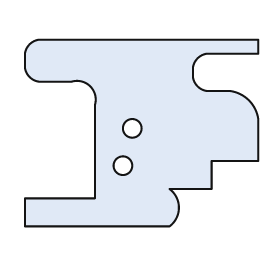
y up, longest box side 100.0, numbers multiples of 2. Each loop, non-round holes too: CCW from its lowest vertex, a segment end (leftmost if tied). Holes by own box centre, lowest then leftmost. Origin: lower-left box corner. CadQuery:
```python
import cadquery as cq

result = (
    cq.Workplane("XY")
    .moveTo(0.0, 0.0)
    .lineTo(62.0, 0.0)
    .threePointArc((66.0, 8.0), (62.0, 16.0))
    .lineTo(80.0, 16.0)
    .lineTo(80.0, 28.0)
    .lineTo(100.0, 28.0)
    .lineTo(100.0, 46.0)
    .threePointArc((96.0, 54.0), (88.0, 58.0))
    .lineTo(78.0, 58.0)
    .threePointArc((74.0, 60.0), (72.0, 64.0))
    .lineTo(72.0, 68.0)
    .threePointArc((74.0, 72.0), (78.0, 74.0))
    .lineTo(100.0, 74.0)
    .lineTo(100.0, 80.0)
    .lineTo(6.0, 80.0)
    .threePointArc((2.0, 78.0), (0.0, 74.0))
    .lineTo(0.0, 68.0)
    .threePointArc((2.0, 64.0), (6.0, 62.0))
    .lineTo(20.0, 62.0)
    .threePointArc((28.0, 60.0), (30.0, 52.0))
    .lineTo(30.0, 12.0)
    .lineTo(0.0, 12.0)
    .close()
    .moveTo(42.0, 26.0)
    .circle(4.0)
    .moveTo(46.0, 42.0)
    .circle(4.0)
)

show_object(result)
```